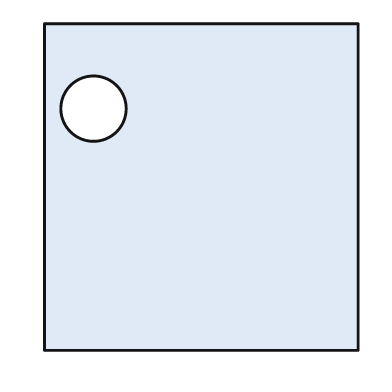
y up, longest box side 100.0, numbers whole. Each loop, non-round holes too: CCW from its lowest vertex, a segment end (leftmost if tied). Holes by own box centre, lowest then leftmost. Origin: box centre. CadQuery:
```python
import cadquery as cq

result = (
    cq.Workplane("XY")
    .moveTo(-48.0, -50.0)
    .lineTo(48.0, -50.0)
    .lineTo(48.0, 50.0)
    .lineTo(-48.0, 50.0)
    .close()
    .moveTo(-33.0, 24.0)
    .circle(10.0)
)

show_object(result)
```